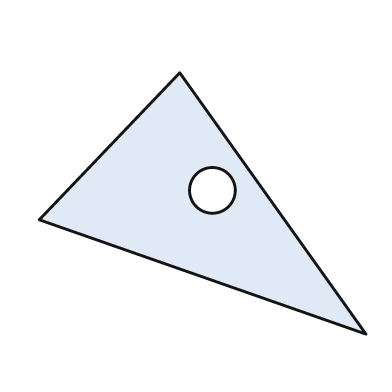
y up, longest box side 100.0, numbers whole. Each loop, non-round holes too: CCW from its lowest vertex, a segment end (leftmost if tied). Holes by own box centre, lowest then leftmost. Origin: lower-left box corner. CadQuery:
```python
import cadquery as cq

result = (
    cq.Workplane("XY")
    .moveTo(100.0, 0.0)
    .lineTo(43.0, 80.0)
    .lineTo(0.0, 35.0)
    .close()
    .moveTo(53.0, 44.0)
    .circle(7.0)
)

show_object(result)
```